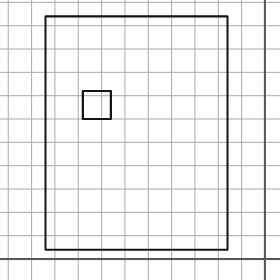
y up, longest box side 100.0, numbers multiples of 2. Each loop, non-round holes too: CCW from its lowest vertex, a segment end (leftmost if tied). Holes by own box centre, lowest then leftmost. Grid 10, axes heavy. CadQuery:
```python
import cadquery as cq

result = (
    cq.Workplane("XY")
    .moveTo(-94.0, 4.0)
    .lineTo(-16.0, 4.0)
    .lineTo(-16.0, 104.0)
    .lineTo(-94.0, 104.0)
    .close()
    .moveTo(-78.0, 60.0)
    .lineTo(-66.0, 60.0)
    .lineTo(-66.0, 72.0)
    .lineTo(-78.0, 72.0)
    .close()
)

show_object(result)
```